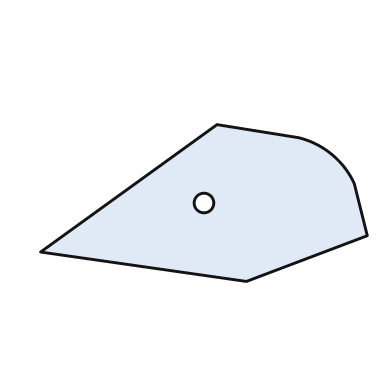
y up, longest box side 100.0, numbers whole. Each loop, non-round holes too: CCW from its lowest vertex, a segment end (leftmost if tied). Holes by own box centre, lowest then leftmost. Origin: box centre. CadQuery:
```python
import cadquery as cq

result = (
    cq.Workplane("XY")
    .moveTo(13.0, -24.0)
    .lineTo(50.0, -10.0)
    .lineTo(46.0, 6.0)
    .threePointArc((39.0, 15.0), (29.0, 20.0))
    .lineTo(4.0, 24.0)
    .lineTo(-50.0, -15.0)
    .close()
    .moveTo(0.0, 0.0)
    .circle(3.0)
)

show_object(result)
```